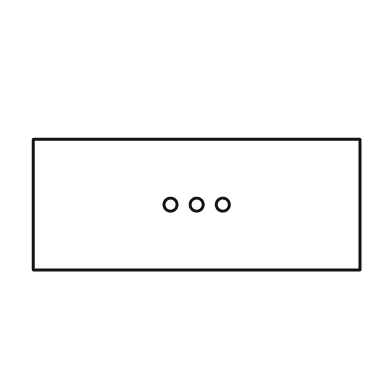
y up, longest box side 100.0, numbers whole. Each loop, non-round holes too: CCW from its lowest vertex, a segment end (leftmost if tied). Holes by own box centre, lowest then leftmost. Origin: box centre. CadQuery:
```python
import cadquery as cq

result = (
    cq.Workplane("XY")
    .moveTo(-50.0, -20.0)
    .lineTo(50.0, -20.0)
    .lineTo(50.0, 20.0)
    .lineTo(-50.0, 20.0)
    .close()
    .moveTo(-8.0, 0.0)
    .circle(2.0)
    .moveTo(0.0, 0.0)
    .circle(2.0)
    .moveTo(8.0, 0.0)
    .circle(2.0)
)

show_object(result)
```